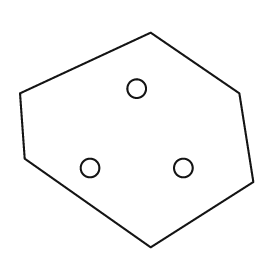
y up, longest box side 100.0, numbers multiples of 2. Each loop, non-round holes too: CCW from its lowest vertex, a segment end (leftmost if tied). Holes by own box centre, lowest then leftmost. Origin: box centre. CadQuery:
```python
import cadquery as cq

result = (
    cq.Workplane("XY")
    .moveTo(6.0, -46.0)
    .lineTo(50.0, -18.0)
    .lineTo(44.0, 20.0)
    .lineTo(6.0, 46.0)
    .lineTo(-50.0, 20.0)
    .lineTo(-48.0, -8.0)
    .close()
    .moveTo(-20.0, -12.0)
    .circle(4.0)
    .moveTo(20.0, -12.0)
    .circle(4.0)
    .moveTo(0.0, 22.0)
    .circle(4.0)
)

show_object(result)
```